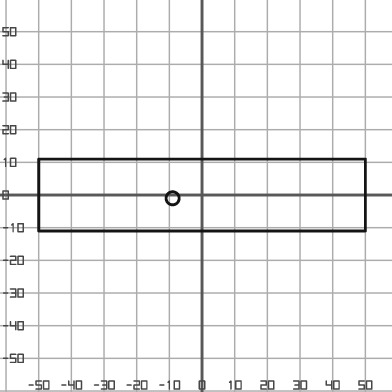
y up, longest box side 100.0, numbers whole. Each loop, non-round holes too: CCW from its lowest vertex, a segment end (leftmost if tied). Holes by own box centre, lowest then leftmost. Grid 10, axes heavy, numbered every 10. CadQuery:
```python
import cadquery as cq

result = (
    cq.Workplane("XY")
    .moveTo(-50.0, -11.0)
    .lineTo(50.0, -11.0)
    .lineTo(50.0, 11.0)
    .lineTo(-50.0, 11.0)
    .close()
    .moveTo(-9.0, -1.0)
    .circle(2.0)
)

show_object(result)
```